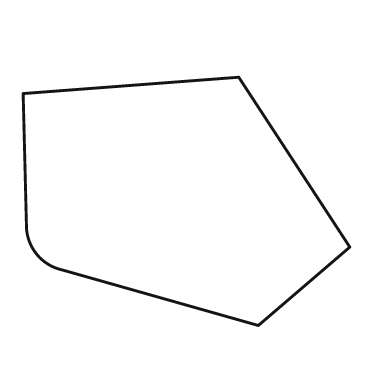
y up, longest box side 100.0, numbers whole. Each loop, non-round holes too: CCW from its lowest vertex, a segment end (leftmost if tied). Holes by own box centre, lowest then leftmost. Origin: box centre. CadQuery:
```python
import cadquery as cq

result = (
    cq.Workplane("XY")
    .moveTo(22.0, -38.0)
    .lineTo(50.0, -14.0)
    .lineTo(16.0, 38.0)
    .lineTo(-50.0, 33.0)
    .lineTo(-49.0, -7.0)
    .threePointArc((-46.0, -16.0), (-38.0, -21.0))
    .close()
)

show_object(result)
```